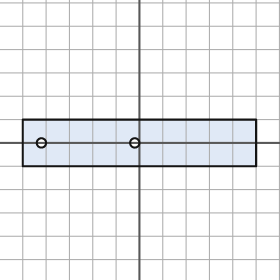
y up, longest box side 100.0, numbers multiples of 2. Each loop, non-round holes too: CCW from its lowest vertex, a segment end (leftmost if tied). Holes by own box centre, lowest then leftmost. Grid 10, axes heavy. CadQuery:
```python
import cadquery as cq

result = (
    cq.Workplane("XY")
    .moveTo(-50.0, -10.0)
    .lineTo(50.0, -10.0)
    .lineTo(50.0, 10.0)
    .lineTo(-50.0, 10.0)
    .close()
    .moveTo(-42.0, 0.0)
    .circle(2.0)
    .moveTo(-2.0, 0.0)
    .circle(2.0)
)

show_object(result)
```